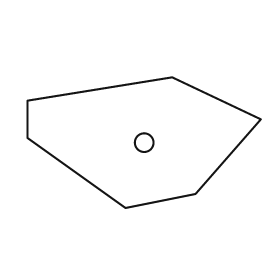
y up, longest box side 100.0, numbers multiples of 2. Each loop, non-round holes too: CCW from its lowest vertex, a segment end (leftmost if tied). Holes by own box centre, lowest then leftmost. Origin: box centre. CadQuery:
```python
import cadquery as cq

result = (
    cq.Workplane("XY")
    .moveTo(-8.0, -28.0)
    .lineTo(22.0, -22.0)
    .lineTo(50.0, 10.0)
    .lineTo(12.0, 28.0)
    .lineTo(-50.0, 18.0)
    .lineTo(-50.0, 2.0)
    .close()
    .moveTo(0.0, 0.0)
    .circle(4.0)
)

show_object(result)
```